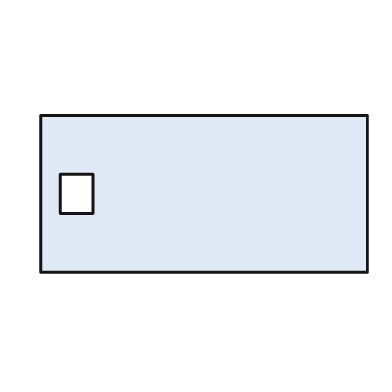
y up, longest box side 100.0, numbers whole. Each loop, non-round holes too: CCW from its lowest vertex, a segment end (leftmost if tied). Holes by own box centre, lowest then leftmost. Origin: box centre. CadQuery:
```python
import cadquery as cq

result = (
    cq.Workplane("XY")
    .moveTo(-50.0, -24.0)
    .lineTo(50.0, -24.0)
    .lineTo(50.0, 24.0)
    .lineTo(-50.0, 24.0)
    .close()
    .moveTo(-44.0, -6.0)
    .lineTo(-34.0, -6.0)
    .lineTo(-34.0, 6.0)
    .lineTo(-44.0, 6.0)
    .close()
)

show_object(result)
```